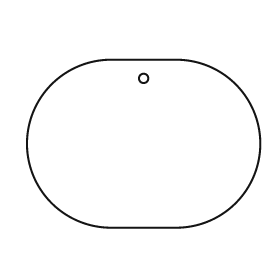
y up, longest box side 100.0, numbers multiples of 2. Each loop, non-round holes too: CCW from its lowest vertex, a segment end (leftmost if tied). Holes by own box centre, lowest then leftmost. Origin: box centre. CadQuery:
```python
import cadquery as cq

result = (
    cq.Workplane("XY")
    .moveTo(-14.0, -36.0)
    .lineTo(14.0, -36.0)
    .threePointArc((50.0, 0.0), (14.0, 36.0))
    .lineTo(-14.0, 36.0)
    .threePointArc((-50.0, 0.0), (-14.0, -36.0))
    .close()
    .moveTo(0.0, 28.0)
    .circle(2.0)
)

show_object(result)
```